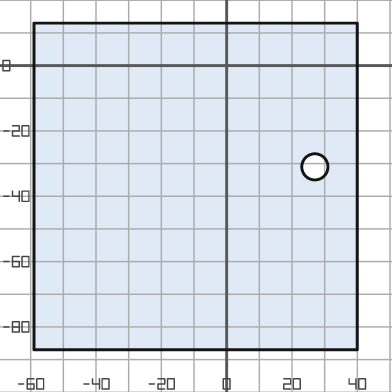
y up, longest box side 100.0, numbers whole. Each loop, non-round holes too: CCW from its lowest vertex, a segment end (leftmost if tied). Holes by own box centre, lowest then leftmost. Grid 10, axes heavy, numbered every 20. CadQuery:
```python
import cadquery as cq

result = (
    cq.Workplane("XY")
    .moveTo(-59.0, -87.0)
    .lineTo(40.0, -87.0)
    .lineTo(40.0, 13.0)
    .lineTo(-59.0, 13.0)
    .close()
    .moveTo(27.0, -31.0)
    .circle(4.0)
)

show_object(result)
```